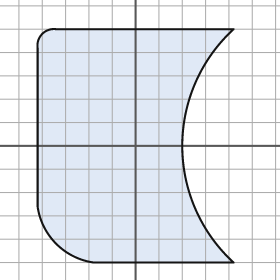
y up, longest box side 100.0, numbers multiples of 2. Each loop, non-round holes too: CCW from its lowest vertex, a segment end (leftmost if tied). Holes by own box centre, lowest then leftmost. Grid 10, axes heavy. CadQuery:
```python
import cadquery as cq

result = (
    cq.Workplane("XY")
    .moveTo(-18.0, -50.0)
    .lineTo(42.0, -50.0)
    .threePointArc((20.0, 0.0), (42.0, 50.0))
    .lineTo(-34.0, 50.0)
    .threePointArc((-40.0, 48.0), (-42.0, 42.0))
    .lineTo(-42.0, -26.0)
    .threePointArc((-34.0, -42.0), (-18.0, -50.0))
    .close()
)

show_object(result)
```